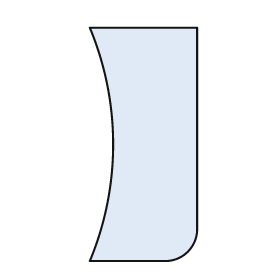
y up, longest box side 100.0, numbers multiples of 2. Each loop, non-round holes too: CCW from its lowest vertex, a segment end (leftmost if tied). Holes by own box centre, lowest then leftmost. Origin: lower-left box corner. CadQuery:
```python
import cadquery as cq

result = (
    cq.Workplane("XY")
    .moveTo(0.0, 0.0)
    .lineTo(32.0, 0.0)
    .threePointArc((42.0, 4.0), (46.0, 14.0))
    .lineTo(46.0, 100.0)
    .lineTo(0.0, 100.0)
    .threePointArc((10.0, 50.0), (0.0, 0.0))
    .close()
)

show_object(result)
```